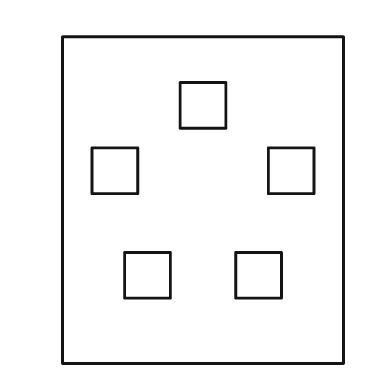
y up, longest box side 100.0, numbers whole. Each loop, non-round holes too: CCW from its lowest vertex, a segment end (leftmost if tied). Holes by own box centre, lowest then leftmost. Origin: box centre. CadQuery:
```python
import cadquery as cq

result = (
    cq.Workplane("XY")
    .moveTo(-43.0, -50.0)
    .lineTo(43.0, -50.0)
    .lineTo(43.0, 50.0)
    .lineTo(-43.0, 50.0)
    .close()
    .moveTo(-24.0, -30.0)
    .lineTo(-10.0, -30.0)
    .lineTo(-10.0, -16.0)
    .lineTo(-24.0, -16.0)
    .close()
    .moveTo(10.0, -30.0)
    .lineTo(24.0, -30.0)
    .lineTo(24.0, -16.0)
    .lineTo(10.0, -16.0)
    .close()
    .moveTo(-34.0, 2.0)
    .lineTo(-20.0, 2.0)
    .lineTo(-20.0, 16.0)
    .lineTo(-34.0, 16.0)
    .close()
    .moveTo(20.0, 2.0)
    .lineTo(34.0, 2.0)
    .lineTo(34.0, 16.0)
    .lineTo(20.0, 16.0)
    .close()
    .moveTo(-7.0, 22.0)
    .lineTo(7.0, 22.0)
    .lineTo(7.0, 36.0)
    .lineTo(-7.0, 36.0)
    .close()
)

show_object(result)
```